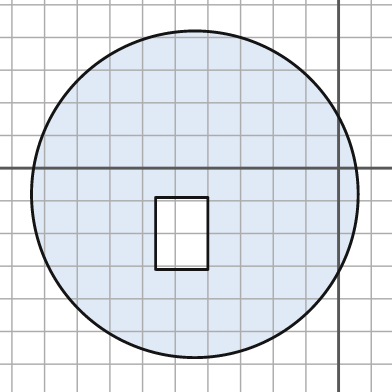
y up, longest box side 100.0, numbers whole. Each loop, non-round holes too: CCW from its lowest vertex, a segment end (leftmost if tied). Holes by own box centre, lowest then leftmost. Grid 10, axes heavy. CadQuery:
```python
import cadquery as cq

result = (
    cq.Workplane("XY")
    .moveTo(-44.0, -8.0)
    .circle(50.0)
    .moveTo(-56.0, -31.0)
    .lineTo(-40.0, -31.0)
    .lineTo(-40.0, -9.0)
    .lineTo(-56.0, -9.0)
    .close()
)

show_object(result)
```